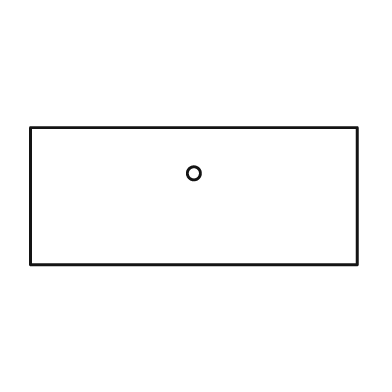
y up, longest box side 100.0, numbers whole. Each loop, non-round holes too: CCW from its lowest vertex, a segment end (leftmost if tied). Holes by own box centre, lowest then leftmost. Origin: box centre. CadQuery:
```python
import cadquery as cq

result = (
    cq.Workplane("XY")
    .moveTo(-50.0, -21.0)
    .lineTo(50.0, -21.0)
    .lineTo(50.0, 21.0)
    .lineTo(-50.0, 21.0)
    .close()
    .moveTo(0.0, 7.0)
    .circle(2.0)
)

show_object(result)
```